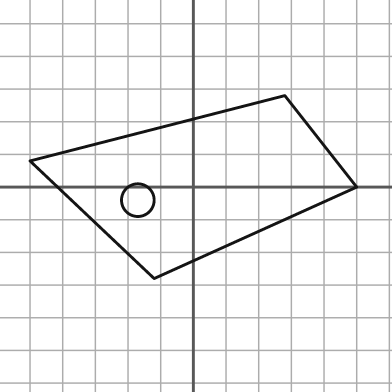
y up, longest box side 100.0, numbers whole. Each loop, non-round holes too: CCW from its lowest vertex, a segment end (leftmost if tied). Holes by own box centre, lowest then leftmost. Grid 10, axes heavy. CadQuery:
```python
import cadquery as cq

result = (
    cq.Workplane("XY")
    .moveTo(-12.0, -28.0)
    .lineTo(50.0, 0.0)
    .lineTo(28.0, 28.0)
    .lineTo(-50.0, 8.0)
    .close()
    .moveTo(-17.0, -4.0)
    .circle(5.0)
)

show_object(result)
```